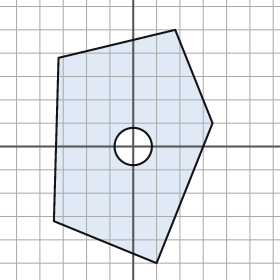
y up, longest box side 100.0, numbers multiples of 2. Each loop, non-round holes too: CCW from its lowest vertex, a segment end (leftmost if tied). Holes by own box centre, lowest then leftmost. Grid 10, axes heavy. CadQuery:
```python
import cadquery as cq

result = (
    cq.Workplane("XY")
    .moveTo(10.0, -50.0)
    .lineTo(34.0, 10.0)
    .lineTo(18.0, 50.0)
    .lineTo(-32.0, 38.0)
    .lineTo(-34.0, -32.0)
    .close()
    .moveTo(0.0, 0.0)
    .circle(8.0)
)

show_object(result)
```